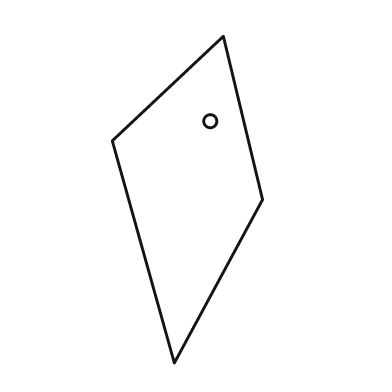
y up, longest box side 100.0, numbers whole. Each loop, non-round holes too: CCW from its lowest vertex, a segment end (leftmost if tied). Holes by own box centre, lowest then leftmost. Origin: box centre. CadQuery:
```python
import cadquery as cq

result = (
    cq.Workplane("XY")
    .moveTo(-4.0, -50.0)
    .lineTo(23.0, 0.0)
    .lineTo(11.0, 50.0)
    .lineTo(-23.0, 18.0)
    .close()
    .moveTo(7.0, 24.0)
    .circle(2.0)
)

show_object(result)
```